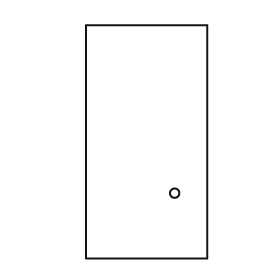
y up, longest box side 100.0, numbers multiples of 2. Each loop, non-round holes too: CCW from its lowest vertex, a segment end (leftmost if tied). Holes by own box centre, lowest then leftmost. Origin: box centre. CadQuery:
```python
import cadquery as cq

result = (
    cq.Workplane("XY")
    .moveTo(-26.0, -50.0)
    .lineTo(26.0, -50.0)
    .lineTo(26.0, 50.0)
    .lineTo(-26.0, 50.0)
    .close()
    .moveTo(12.0, -22.0)
    .circle(2.0)
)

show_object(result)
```